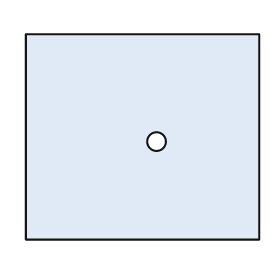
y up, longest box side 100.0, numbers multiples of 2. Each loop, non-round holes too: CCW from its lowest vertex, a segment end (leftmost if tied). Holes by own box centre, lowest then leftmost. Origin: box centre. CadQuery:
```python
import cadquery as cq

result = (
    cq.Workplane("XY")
    .moveTo(-50.0, -44.0)
    .lineTo(50.0, -44.0)
    .lineTo(50.0, 44.0)
    .lineTo(-50.0, 44.0)
    .close()
    .moveTo(6.0, -2.0)
    .circle(4.0)
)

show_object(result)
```